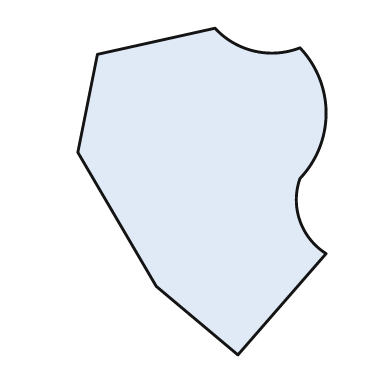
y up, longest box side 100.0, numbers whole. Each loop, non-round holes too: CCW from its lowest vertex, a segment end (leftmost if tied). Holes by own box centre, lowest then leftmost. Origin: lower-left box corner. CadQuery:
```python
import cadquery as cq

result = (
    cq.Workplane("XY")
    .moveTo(49.0, 0.0)
    .lineTo(76.0, 31.0)
    .threePointArc((68.0, 41.0), (68.0, 54.0))
    .threePointArc((76.0, 74.0), (68.0, 94.0))
    .threePointArc((54.0, 93.0), (42.0, 100.0))
    .lineTo(6.0, 92.0)
    .lineTo(0.0, 62.0)
    .lineTo(24.0, 21.0)
    .close()
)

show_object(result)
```